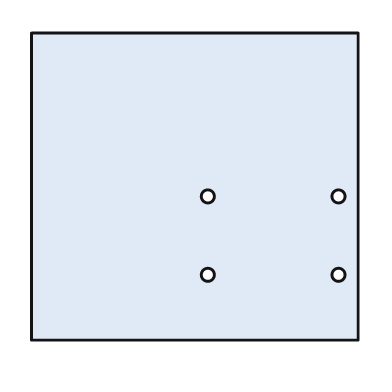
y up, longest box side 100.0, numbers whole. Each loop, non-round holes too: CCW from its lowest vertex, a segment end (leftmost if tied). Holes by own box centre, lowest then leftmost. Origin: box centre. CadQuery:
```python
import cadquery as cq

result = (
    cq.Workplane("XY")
    .moveTo(-50.0, -47.0)
    .lineTo(50.0, -47.0)
    .lineTo(50.0, 47.0)
    .lineTo(-50.0, 47.0)
    .close()
    .moveTo(4.0, -27.0)
    .circle(2.0)
    .moveTo(44.0, -27.0)
    .circle(2.0)
    .moveTo(4.0, -3.0)
    .circle(2.0)
    .moveTo(44.0, -3.0)
    .circle(2.0)
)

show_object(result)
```